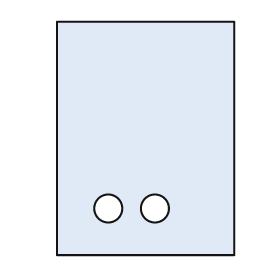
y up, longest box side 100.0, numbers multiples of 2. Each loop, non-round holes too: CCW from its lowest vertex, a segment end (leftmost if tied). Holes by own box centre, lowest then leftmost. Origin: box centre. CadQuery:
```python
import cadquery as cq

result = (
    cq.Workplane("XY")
    .moveTo(-38.0, -50.0)
    .lineTo(38.0, -50.0)
    .lineTo(38.0, 50.0)
    .lineTo(-38.0, 50.0)
    .close()
    .moveTo(-16.0, -30.0)
    .circle(6.0)
    .moveTo(4.0, -30.0)
    .circle(6.0)
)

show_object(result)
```